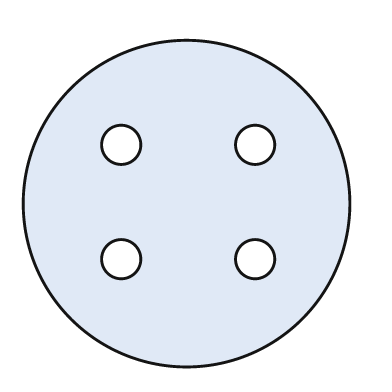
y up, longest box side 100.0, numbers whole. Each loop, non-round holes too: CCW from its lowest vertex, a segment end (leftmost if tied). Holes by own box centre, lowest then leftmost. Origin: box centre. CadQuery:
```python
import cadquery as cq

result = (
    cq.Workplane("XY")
    .moveTo(0.0, 0.0)
    .circle(50.0)
    .moveTo(-20.0, -17.0)
    .circle(6.0)
    .moveTo(21.0, -17.0)
    .circle(6.0)
    .moveTo(-20.0, 18.0)
    .circle(6.0)
    .moveTo(21.0, 18.0)
    .circle(6.0)
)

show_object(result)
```